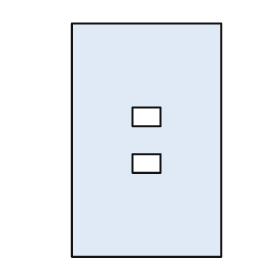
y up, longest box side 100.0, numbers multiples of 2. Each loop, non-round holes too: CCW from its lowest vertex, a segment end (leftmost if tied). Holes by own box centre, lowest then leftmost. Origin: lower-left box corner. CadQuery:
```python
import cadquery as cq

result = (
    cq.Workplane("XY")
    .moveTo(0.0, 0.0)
    .lineTo(64.0, 0.0)
    .lineTo(64.0, 100.0)
    .lineTo(0.0, 100.0)
    .close()
    .moveTo(26.0, 36.0)
    .lineTo(38.0, 36.0)
    .lineTo(38.0, 44.0)
    .lineTo(26.0, 44.0)
    .close()
    .moveTo(26.0, 56.0)
    .lineTo(38.0, 56.0)
    .lineTo(38.0, 64.0)
    .lineTo(26.0, 64.0)
    .close()
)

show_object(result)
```